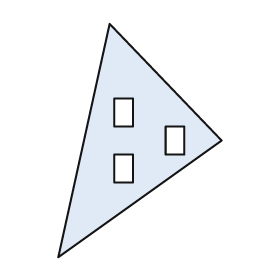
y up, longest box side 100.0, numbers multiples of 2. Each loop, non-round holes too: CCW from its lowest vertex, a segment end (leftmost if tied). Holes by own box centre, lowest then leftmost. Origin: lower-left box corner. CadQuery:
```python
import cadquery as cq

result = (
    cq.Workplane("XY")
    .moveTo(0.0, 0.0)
    .lineTo(70.0, 50.0)
    .lineTo(22.0, 100.0)
    .close()
    .moveTo(24.0, 32.0)
    .lineTo(32.0, 32.0)
    .lineTo(32.0, 44.0)
    .lineTo(24.0, 44.0)
    .close()
    .moveTo(46.0, 44.0)
    .lineTo(54.0, 44.0)
    .lineTo(54.0, 56.0)
    .lineTo(46.0, 56.0)
    .close()
    .moveTo(24.0, 56.0)
    .lineTo(32.0, 56.0)
    .lineTo(32.0, 68.0)
    .lineTo(24.0, 68.0)
    .close()
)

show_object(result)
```